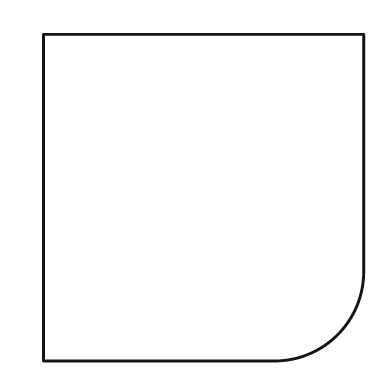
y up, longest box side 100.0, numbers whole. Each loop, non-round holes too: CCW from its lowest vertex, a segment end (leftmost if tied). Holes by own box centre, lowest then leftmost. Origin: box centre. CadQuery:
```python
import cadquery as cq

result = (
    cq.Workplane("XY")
    .moveTo(-49.0, -50.0)
    .lineTo(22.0, -50.0)
    .threePointArc((41.0, -42.0), (49.0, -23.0))
    .lineTo(49.0, 50.0)
    .lineTo(-49.0, 50.0)
    .close()
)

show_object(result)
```